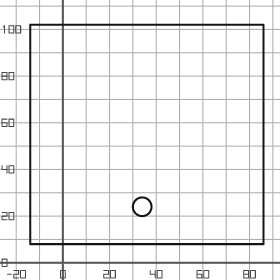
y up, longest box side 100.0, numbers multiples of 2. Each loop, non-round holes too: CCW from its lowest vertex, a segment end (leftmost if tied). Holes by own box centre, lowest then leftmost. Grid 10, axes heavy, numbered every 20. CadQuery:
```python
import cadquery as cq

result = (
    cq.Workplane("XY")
    .moveTo(-14.0, 8.0)
    .lineTo(86.0, 8.0)
    .lineTo(86.0, 102.0)
    .lineTo(-14.0, 102.0)
    .close()
    .moveTo(34.0, 24.0)
    .circle(4.0)
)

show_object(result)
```